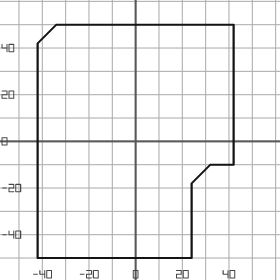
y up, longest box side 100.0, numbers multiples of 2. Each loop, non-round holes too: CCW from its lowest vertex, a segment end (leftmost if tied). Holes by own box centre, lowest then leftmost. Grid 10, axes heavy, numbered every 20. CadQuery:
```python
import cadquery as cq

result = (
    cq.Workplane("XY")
    .moveTo(-42.0, -50.0)
    .lineTo(24.0, -50.0)
    .lineTo(24.0, -18.0)
    .lineTo(32.0, -10.0)
    .lineTo(42.0, -10.0)
    .lineTo(42.0, 50.0)
    .lineTo(-34.0, 50.0)
    .lineTo(-42.0, 42.0)
    .close()
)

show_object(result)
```